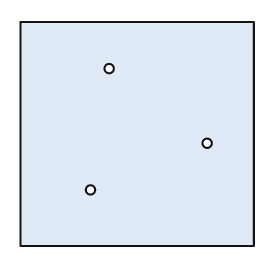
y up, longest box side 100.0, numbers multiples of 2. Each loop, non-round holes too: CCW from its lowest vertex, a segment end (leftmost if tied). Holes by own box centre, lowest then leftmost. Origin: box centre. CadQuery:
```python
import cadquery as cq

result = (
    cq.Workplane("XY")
    .moveTo(-50.0, -48.0)
    .lineTo(50.0, -48.0)
    .lineTo(50.0, 48.0)
    .lineTo(-50.0, 48.0)
    .close()
    .moveTo(-20.0, -24.0)
    .circle(2.0)
    .moveTo(30.0, -4.0)
    .circle(2.0)
    .moveTo(-12.0, 28.0)
    .circle(2.0)
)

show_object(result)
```